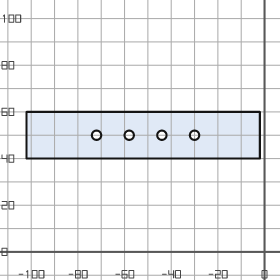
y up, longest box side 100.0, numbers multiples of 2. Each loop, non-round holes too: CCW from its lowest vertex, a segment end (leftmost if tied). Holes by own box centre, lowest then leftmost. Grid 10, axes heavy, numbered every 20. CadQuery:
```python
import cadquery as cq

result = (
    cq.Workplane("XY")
    .moveTo(-102.0, 40.0)
    .lineTo(-2.0, 40.0)
    .lineTo(-2.0, 60.0)
    .lineTo(-102.0, 60.0)
    .close()
    .moveTo(-72.0, 50.0)
    .circle(2.0)
    .moveTo(-58.0, 50.0)
    .circle(2.0)
    .moveTo(-44.0, 50.0)
    .circle(2.0)
    .moveTo(-30.0, 50.0)
    .circle(2.0)
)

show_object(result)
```